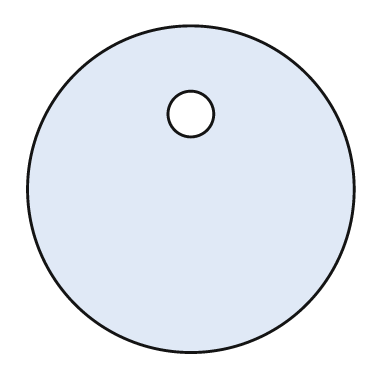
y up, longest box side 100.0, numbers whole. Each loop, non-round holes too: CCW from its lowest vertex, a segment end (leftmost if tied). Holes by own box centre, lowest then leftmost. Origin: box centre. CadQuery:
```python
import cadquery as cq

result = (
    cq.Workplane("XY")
    .moveTo(0.0, 0.0)
    .circle(50.0)
    .moveTo(0.0, 23.0)
    .circle(7.0)
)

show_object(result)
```